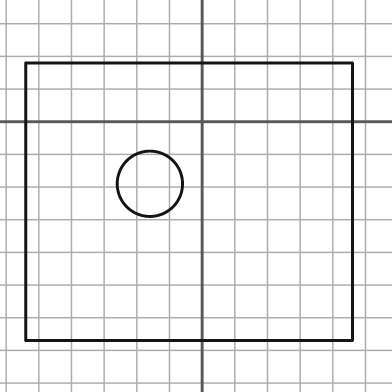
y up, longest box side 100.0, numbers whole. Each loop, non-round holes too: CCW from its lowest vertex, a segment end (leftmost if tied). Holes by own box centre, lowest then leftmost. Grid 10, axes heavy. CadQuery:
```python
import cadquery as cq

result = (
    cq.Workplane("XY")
    .moveTo(-54.0, -67.0)
    .lineTo(46.0, -67.0)
    .lineTo(46.0, 18.0)
    .lineTo(-54.0, 18.0)
    .close()
    .moveTo(-16.0, -19.0)
    .circle(10.0)
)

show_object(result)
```